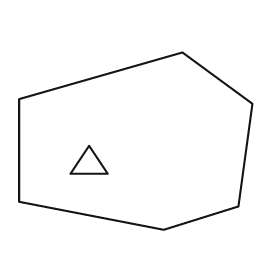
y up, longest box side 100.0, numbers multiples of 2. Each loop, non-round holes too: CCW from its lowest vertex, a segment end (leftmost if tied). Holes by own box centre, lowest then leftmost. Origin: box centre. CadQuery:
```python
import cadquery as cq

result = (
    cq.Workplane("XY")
    .moveTo(12.0, -38.0)
    .lineTo(44.0, -28.0)
    .lineTo(50.0, 16.0)
    .lineTo(20.0, 38.0)
    .lineTo(-50.0, 18.0)
    .lineTo(-50.0, -26.0)
    .close()
    .moveTo(-28.0, -14.0)
    .lineTo(-12.0, -14.0)
    .lineTo(-20.0, -2.0)
    .close()
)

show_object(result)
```